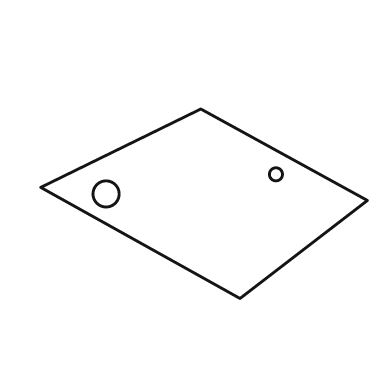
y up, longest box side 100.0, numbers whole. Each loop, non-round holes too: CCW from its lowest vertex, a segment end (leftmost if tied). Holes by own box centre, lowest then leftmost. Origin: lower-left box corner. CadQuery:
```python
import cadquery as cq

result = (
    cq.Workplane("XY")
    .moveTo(61.0, 0.0)
    .lineTo(100.0, 30.0)
    .lineTo(49.0, 58.0)
    .lineTo(0.0, 34.0)
    .close()
    .moveTo(20.0, 32.0)
    .circle(4.0)
    .moveTo(72.0, 38.0)
    .circle(2.0)
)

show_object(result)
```